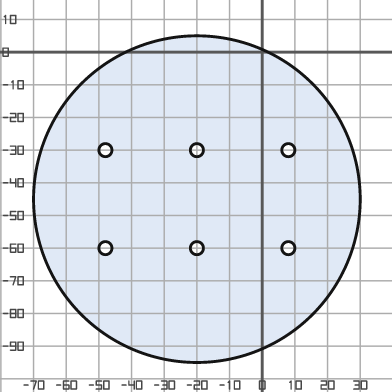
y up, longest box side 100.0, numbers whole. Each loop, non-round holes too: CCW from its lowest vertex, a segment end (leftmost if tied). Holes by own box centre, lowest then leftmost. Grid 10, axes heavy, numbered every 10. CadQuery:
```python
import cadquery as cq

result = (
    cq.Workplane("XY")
    .moveTo(-20.0, -45.0)
    .circle(50.0)
    .moveTo(-48.0, -60.0)
    .circle(2.0)
    .moveTo(-20.0, -60.0)
    .circle(2.0)
    .moveTo(8.0, -60.0)
    .circle(2.0)
    .moveTo(-48.0, -30.0)
    .circle(2.0)
    .moveTo(-20.0, -30.0)
    .circle(2.0)
    .moveTo(8.0, -30.0)
    .circle(2.0)
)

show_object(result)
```